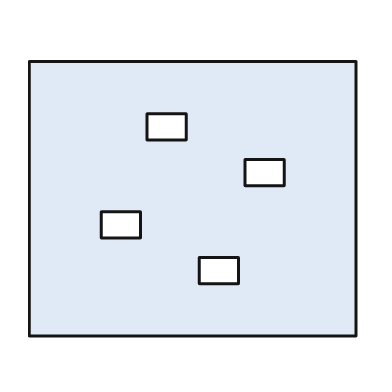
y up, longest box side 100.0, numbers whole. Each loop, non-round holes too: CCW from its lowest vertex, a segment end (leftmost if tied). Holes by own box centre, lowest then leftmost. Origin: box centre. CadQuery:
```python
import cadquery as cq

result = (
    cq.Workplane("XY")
    .moveTo(-50.0, -42.0)
    .lineTo(50.0, -42.0)
    .lineTo(50.0, 42.0)
    .lineTo(-50.0, 42.0)
    .close()
    .moveTo(2.0, -26.0)
    .lineTo(14.0, -26.0)
    .lineTo(14.0, -18.0)
    .lineTo(2.0, -18.0)
    .close()
    .moveTo(-28.0, -12.0)
    .lineTo(-16.0, -12.0)
    .lineTo(-16.0, -4.0)
    .lineTo(-28.0, -4.0)
    .close()
    .moveTo(16.0, 4.0)
    .lineTo(28.0, 4.0)
    .lineTo(28.0, 12.0)
    .lineTo(16.0, 12.0)
    .close()
    .moveTo(-14.0, 18.0)
    .lineTo(-2.0, 18.0)
    .lineTo(-2.0, 26.0)
    .lineTo(-14.0, 26.0)
    .close()
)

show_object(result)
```